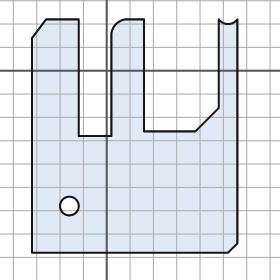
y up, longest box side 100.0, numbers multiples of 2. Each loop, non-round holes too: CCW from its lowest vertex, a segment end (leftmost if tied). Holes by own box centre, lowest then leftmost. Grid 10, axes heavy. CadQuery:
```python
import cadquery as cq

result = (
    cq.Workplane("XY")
    .moveTo(-32.0, -78.0)
    .lineTo(52.0, -78.0)
    .lineTo(56.0, -74.0)
    .lineTo(56.0, 22.0)
    .threePointArc((52.0, 20.0), (48.0, 22.0))
    .lineTo(48.0, -16.0)
    .lineTo(38.0, -26.0)
    .lineTo(16.0, -26.0)
    .lineTo(16.0, 22.0)
    .lineTo(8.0, 22.0)
    .threePointArc((4.0, 20.0), (2.0, 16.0))
    .lineTo(2.0, -28.0)
    .lineTo(-12.0, -28.0)
    .lineTo(-12.0, 22.0)
    .lineTo(-26.0, 22.0)
    .lineTo(-32.0, 14.0)
    .close()
    .moveTo(-16.0, -58.0)
    .circle(4.0)
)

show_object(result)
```